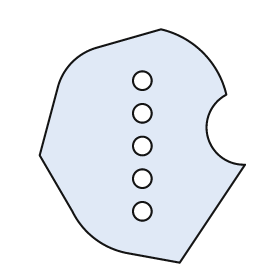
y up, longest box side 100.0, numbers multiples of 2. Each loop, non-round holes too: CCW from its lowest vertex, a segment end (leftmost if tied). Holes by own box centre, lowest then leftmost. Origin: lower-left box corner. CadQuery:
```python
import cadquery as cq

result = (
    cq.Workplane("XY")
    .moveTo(60.0, 0.0)
    .lineTo(88.0, 42.0)
    .threePointArc((72.0, 54.0), (80.0, 72.0))
    .threePointArc((70.0, 90.0), (52.0, 100.0))
    .lineTo(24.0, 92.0)
    .threePointArc((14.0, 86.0), (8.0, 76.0))
    .lineTo(0.0, 46.0)
    .lineTo(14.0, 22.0)
    .threePointArc((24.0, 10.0), (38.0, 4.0))
    .close()
    .moveTo(44.0, 22.0)
    .circle(4.0)
    .moveTo(44.0, 36.0)
    .circle(4.0)
    .moveTo(44.0, 50.0)
    .circle(4.0)
    .moveTo(44.0, 64.0)
    .circle(4.0)
    .moveTo(44.0, 78.0)
    .circle(4.0)
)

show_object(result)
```